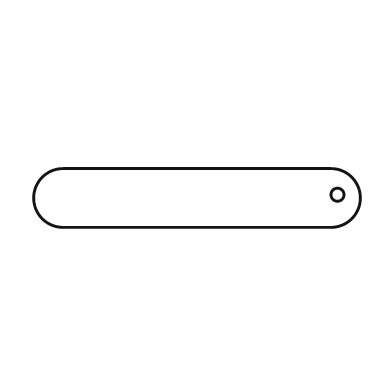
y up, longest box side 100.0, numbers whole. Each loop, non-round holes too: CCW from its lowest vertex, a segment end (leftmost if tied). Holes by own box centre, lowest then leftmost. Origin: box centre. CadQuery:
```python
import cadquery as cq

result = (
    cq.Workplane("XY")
    .moveTo(-41.0, -9.0)
    .lineTo(41.0, -9.0)
    .threePointArc((50.0, 0.0), (41.0, 9.0))
    .lineTo(-41.0, 9.0)
    .threePointArc((-50.0, 0.0), (-41.0, -9.0))
    .close()
    .moveTo(43.0, 1.0)
    .circle(2.0)
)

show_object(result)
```